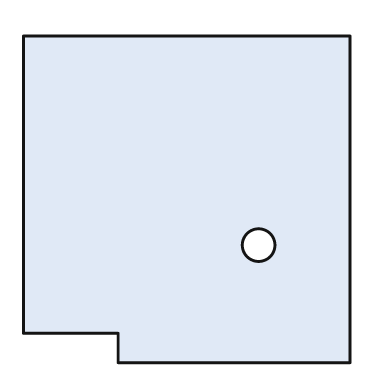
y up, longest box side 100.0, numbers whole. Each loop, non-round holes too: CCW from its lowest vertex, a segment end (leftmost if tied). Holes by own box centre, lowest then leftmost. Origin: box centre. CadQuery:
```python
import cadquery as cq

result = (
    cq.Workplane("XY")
    .moveTo(-21.0, -50.0)
    .lineTo(50.0, -50.0)
    .lineTo(50.0, 50.0)
    .lineTo(-50.0, 50.0)
    .lineTo(-50.0, -41.0)
    .lineTo(-21.0, -41.0)
    .close()
    .moveTo(22.0, -14.0)
    .circle(5.0)
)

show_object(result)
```